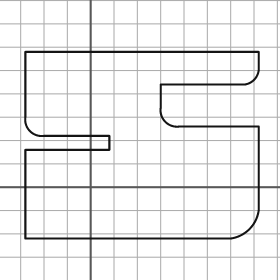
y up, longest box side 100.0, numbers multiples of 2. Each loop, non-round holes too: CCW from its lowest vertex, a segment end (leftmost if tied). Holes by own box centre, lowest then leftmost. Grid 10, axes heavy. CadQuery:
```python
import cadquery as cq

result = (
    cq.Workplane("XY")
    .moveTo(-28.0, -22.0)
    .lineTo(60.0, -22.0)
    .threePointArc((68.0, -18.0), (72.0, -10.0))
    .lineTo(72.0, 26.0)
    .lineTo(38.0, 26.0)
    .threePointArc((32.0, 28.0), (30.0, 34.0))
    .lineTo(30.0, 44.0)
    .lineTo(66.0, 44.0)
    .threePointArc((70.0, 46.0), (72.0, 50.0))
    .lineTo(72.0, 58.0)
    .lineTo(-28.0, 58.0)
    .lineTo(-28.0, 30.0)
    .threePointArc((-26.0, 24.0), (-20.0, 22.0))
    .lineTo(8.0, 22.0)
    .lineTo(8.0, 16.0)
    .lineTo(-28.0, 16.0)
    .close()
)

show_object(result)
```